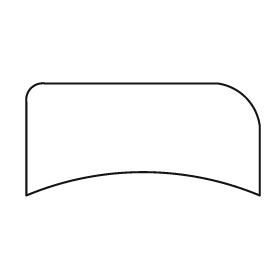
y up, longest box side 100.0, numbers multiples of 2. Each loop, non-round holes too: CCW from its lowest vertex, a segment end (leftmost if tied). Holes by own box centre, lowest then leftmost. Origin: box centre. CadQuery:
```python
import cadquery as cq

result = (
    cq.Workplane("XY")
    .moveTo(-50.0, -24.0)
    .threePointArc((0.0, -14.0), (50.0, -24.0))
    .lineTo(50.0, 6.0)
    .threePointArc((44.0, 18.0), (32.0, 24.0))
    .lineTo(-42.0, 24.0)
    .threePointArc((-48.0, 22.0), (-50.0, 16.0))
    .close()
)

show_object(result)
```